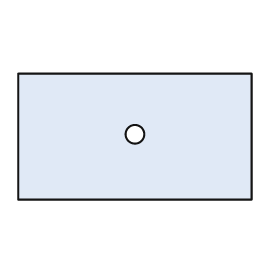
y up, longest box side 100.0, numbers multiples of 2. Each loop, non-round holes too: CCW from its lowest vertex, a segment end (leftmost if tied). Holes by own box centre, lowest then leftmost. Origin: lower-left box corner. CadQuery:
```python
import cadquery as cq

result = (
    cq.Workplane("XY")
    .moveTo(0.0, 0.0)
    .lineTo(100.0, 0.0)
    .lineTo(100.0, 54.0)
    .lineTo(0.0, 54.0)
    .close()
    .moveTo(50.0, 28.0)
    .circle(4.0)
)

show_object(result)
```